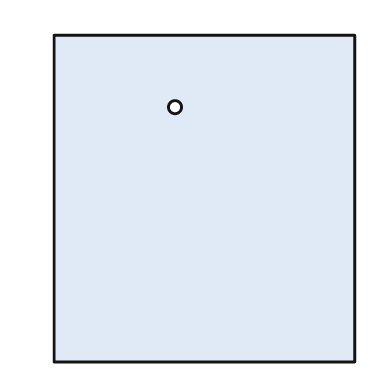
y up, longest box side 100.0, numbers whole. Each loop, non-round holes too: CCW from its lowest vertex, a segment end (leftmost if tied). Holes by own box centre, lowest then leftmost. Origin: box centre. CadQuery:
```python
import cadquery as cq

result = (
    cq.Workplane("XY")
    .moveTo(-46.0, -50.0)
    .lineTo(46.0, -50.0)
    .lineTo(46.0, 50.0)
    .lineTo(-46.0, 50.0)
    .close()
    .moveTo(-9.0, 28.0)
    .circle(2.0)
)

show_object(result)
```